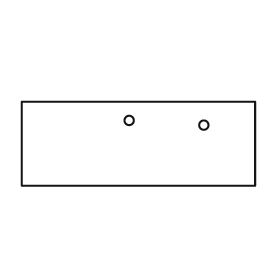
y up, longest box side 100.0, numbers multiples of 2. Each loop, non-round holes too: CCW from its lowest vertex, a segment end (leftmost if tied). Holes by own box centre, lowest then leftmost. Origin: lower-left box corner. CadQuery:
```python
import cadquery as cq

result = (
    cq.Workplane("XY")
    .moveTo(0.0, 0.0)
    .lineTo(100.0, 0.0)
    .lineTo(100.0, 36.0)
    .lineTo(0.0, 36.0)
    .close()
    .moveTo(78.0, 26.0)
    .circle(2.0)
    .moveTo(46.0, 28.0)
    .circle(2.0)
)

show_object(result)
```